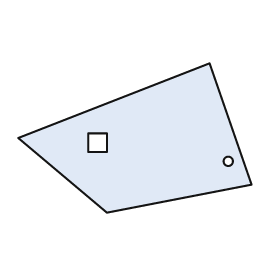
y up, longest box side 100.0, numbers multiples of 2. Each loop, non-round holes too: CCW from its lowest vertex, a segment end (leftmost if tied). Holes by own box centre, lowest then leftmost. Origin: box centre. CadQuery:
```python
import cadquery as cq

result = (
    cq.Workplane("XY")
    .moveTo(-12.0, -32.0)
    .lineTo(50.0, -20.0)
    .lineTo(32.0, 32.0)
    .lineTo(-50.0, 0.0)
    .close()
    .moveTo(40.0, -10.0)
    .circle(2.0)
    .moveTo(-20.0, -6.0)
    .lineTo(-12.0, -6.0)
    .lineTo(-12.0, 2.0)
    .lineTo(-20.0, 2.0)
    .close()
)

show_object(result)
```